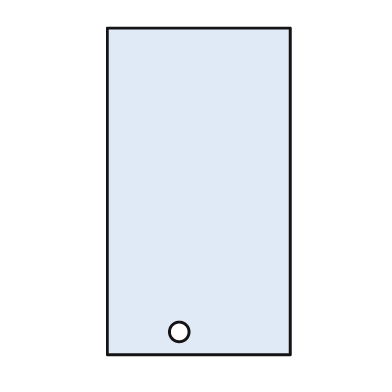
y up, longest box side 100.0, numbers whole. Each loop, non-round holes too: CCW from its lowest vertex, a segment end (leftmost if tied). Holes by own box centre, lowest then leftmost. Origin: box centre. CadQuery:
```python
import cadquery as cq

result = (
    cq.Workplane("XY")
    .moveTo(-28.0, -50.0)
    .lineTo(28.0, -50.0)
    .lineTo(28.0, 50.0)
    .lineTo(-28.0, 50.0)
    .close()
    .moveTo(-6.0, -43.0)
    .circle(3.0)
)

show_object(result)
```